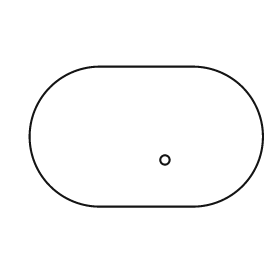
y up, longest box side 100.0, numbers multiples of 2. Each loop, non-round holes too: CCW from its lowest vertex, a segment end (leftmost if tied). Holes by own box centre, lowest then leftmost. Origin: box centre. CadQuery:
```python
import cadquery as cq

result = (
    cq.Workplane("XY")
    .moveTo(-20.0, -30.0)
    .lineTo(20.0, -30.0)
    .threePointArc((50.0, 0.0), (20.0, 30.0))
    .lineTo(-20.0, 30.0)
    .threePointArc((-50.0, 0.0), (-20.0, -30.0))
    .close()
    .moveTo(8.0, -10.0)
    .circle(2.0)
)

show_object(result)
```